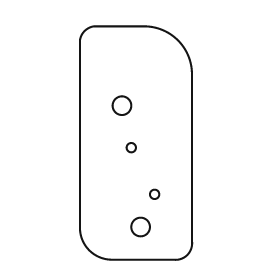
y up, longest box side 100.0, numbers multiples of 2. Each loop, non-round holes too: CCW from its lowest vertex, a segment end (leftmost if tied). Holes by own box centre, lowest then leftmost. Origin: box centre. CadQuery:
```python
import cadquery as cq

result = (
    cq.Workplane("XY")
    .moveTo(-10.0, -50.0)
    .lineTo(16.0, -50.0)
    .threePointArc((22.0, -48.0), (24.0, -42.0))
    .lineTo(24.0, 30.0)
    .threePointArc((18.0, 44.0), (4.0, 50.0))
    .lineTo(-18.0, 50.0)
    .threePointArc((-22.0, 48.0), (-24.0, 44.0))
    .lineTo(-24.0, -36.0)
    .threePointArc((-20.0, -46.0), (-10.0, -50.0))
    .close()
    .moveTo(2.0, -36.0)
    .circle(4.0)
    .moveTo(8.0, -22.0)
    .circle(2.0)
    .moveTo(-2.0, -2.0)
    .circle(2.0)
    .moveTo(-6.0, 16.0)
    .circle(4.0)
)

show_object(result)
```